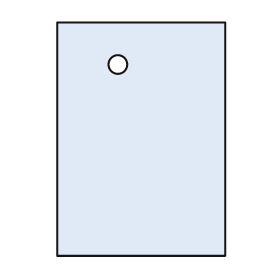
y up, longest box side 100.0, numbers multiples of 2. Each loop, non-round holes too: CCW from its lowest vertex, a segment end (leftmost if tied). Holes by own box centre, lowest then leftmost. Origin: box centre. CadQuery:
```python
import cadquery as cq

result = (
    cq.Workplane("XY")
    .moveTo(-36.0, -50.0)
    .lineTo(36.0, -50.0)
    .lineTo(36.0, 50.0)
    .lineTo(-36.0, 50.0)
    .close()
    .moveTo(-10.0, 32.0)
    .circle(4.0)
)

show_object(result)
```